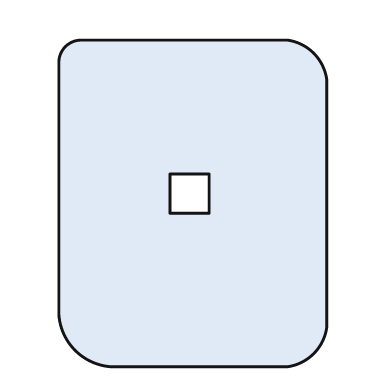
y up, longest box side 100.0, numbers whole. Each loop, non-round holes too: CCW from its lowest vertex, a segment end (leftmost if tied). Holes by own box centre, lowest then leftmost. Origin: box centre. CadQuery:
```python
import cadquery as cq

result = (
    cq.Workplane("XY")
    .moveTo(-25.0, -50.0)
    .lineTo(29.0, -50.0)
    .threePointArc((37.0, -46.0), (41.0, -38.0))
    .lineTo(41.0, 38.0)
    .threePointArc((37.0, 46.0), (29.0, 50.0))
    .lineTo(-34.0, 50.0)
    .threePointArc((-39.0, 48.0), (-41.0, 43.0))
    .lineTo(-41.0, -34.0)
    .threePointArc((-36.0, -45.0), (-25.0, -50.0))
    .close()
    .moveTo(-7.0, -3.0)
    .lineTo(5.0, -3.0)
    .lineTo(5.0, 9.0)
    .lineTo(-7.0, 9.0)
    .close()
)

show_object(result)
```